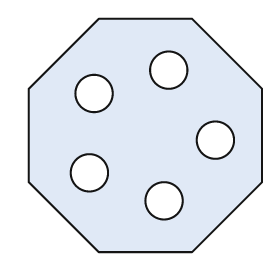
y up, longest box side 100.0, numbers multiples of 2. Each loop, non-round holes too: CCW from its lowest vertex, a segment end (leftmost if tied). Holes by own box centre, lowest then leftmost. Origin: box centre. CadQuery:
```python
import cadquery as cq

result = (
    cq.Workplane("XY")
    .moveTo(-20.0, -50.0)
    .lineTo(20.0, -50.0)
    .lineTo(50.0, -20.0)
    .lineTo(50.0, 20.0)
    .lineTo(20.0, 50.0)
    .lineTo(-20.0, 50.0)
    .lineTo(-50.0, 20.0)
    .lineTo(-50.0, -20.0)
    .close()
    .moveTo(8.0, -28.0)
    .circle(8.0)
    .moveTo(-24.0, -16.0)
    .circle(8.0)
    .moveTo(30.0, -2.0)
    .circle(8.0)
    .moveTo(-22.0, 18.0)
    .circle(8.0)
    .moveTo(10.0, 28.0)
    .circle(8.0)
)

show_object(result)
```